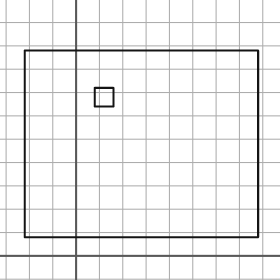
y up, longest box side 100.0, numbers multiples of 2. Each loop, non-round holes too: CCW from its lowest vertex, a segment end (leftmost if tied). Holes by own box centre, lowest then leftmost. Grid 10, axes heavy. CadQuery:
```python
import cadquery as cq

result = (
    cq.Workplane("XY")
    .moveTo(-22.0, 8.0)
    .lineTo(78.0, 8.0)
    .lineTo(78.0, 88.0)
    .lineTo(-22.0, 88.0)
    .close()
    .moveTo(8.0, 64.0)
    .lineTo(16.0, 64.0)
    .lineTo(16.0, 72.0)
    .lineTo(8.0, 72.0)
    .close()
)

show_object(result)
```